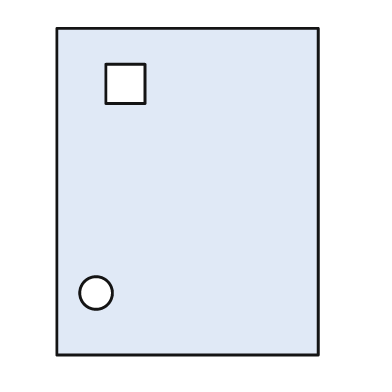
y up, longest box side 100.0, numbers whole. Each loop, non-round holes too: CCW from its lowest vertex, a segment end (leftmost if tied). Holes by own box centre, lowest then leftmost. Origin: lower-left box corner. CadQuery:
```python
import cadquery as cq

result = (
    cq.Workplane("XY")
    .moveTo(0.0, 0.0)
    .lineTo(80.0, 0.0)
    .lineTo(80.0, 100.0)
    .lineTo(0.0, 100.0)
    .close()
    .moveTo(12.0, 19.0)
    .circle(5.0)
    .moveTo(15.0, 77.0)
    .lineTo(27.0, 77.0)
    .lineTo(27.0, 89.0)
    .lineTo(15.0, 89.0)
    .close()
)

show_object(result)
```